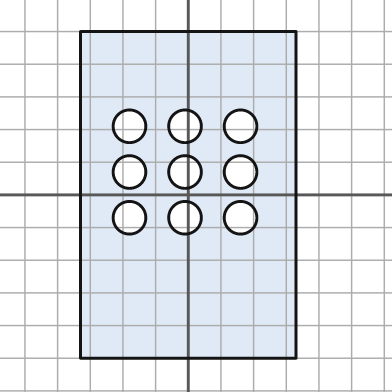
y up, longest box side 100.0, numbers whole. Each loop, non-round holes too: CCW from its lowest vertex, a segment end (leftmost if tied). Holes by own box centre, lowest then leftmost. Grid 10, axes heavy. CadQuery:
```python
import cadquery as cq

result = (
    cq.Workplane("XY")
    .moveTo(-33.0, -50.0)
    .lineTo(33.0, -50.0)
    .lineTo(33.0, 50.0)
    .lineTo(-33.0, 50.0)
    .close()
    .moveTo(-18.0, -7.0)
    .circle(5.0)
    .moveTo(-1.0, -7.0)
    .circle(5.0)
    .moveTo(16.0, -7.0)
    .circle(5.0)
    .moveTo(-18.0, 7.0)
    .circle(5.0)
    .moveTo(-1.0, 7.0)
    .circle(5.0)
    .moveTo(16.0, 7.0)
    .circle(5.0)
    .moveTo(-18.0, 21.0)
    .circle(5.0)
    .moveTo(-1.0, 21.0)
    .circle(5.0)
    .moveTo(16.0, 21.0)
    .circle(5.0)
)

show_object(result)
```